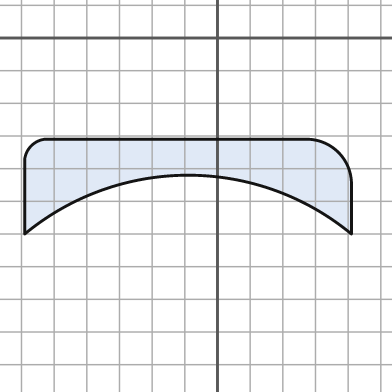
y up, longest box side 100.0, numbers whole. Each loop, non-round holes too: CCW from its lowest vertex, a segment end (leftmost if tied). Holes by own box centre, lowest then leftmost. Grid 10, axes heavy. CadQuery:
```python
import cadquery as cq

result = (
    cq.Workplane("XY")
    .moveTo(-59.0, -60.0)
    .threePointArc((-9.0, -42.0), (41.0, -60.0))
    .lineTo(41.0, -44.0)
    .threePointArc((37.0, -35.0), (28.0, -31.0))
    .lineTo(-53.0, -31.0)
    .threePointArc((-57.0, -33.0), (-59.0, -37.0))
    .close()
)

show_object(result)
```